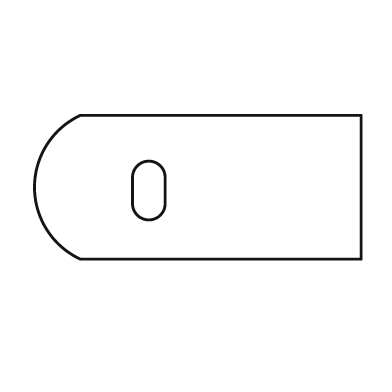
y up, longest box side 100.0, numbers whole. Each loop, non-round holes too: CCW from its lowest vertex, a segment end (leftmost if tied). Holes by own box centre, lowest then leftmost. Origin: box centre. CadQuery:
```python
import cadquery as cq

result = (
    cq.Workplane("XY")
    .moveTo(-36.0, -22.0)
    .lineTo(50.0, -22.0)
    .lineTo(50.0, 22.0)
    .lineTo(-36.0, 22.0)
    .threePointArc((-50.0, 0.0), (-36.0, -22.0))
    .close()
    .moveTo(-20.0, -5.0)
    .threePointArc((-15.0, -10.0), (-10.0, -5.0))
    .lineTo(-10.0, 3.0)
    .threePointArc((-15.0, 8.0), (-20.0, 3.0))
    .close()
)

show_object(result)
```